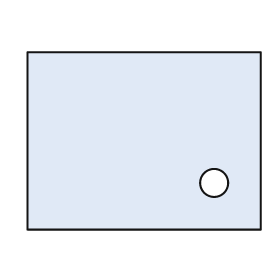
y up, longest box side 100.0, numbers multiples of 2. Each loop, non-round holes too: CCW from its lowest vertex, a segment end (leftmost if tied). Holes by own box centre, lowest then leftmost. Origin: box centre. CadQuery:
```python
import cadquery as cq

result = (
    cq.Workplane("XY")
    .moveTo(-50.0, -38.0)
    .lineTo(50.0, -38.0)
    .lineTo(50.0, 38.0)
    .lineTo(-50.0, 38.0)
    .close()
    .moveTo(30.0, -18.0)
    .circle(6.0)
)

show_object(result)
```